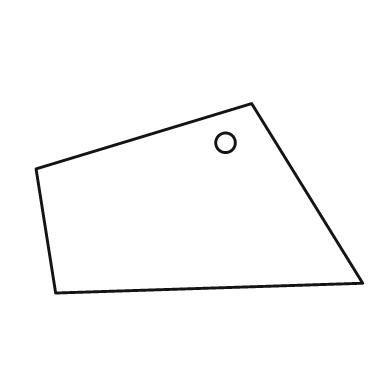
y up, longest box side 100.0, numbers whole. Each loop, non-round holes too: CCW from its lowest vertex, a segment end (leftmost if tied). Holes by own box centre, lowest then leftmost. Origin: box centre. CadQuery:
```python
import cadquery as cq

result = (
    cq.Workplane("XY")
    .moveTo(-44.0, -29.0)
    .lineTo(50.0, -26.0)
    .lineTo(16.0, 29.0)
    .lineTo(-50.0, 9.0)
    .close()
    .moveTo(8.0, 17.0)
    .circle(3.0)
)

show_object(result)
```